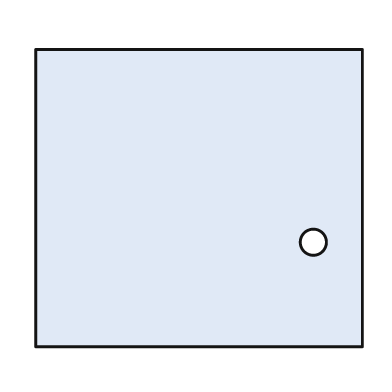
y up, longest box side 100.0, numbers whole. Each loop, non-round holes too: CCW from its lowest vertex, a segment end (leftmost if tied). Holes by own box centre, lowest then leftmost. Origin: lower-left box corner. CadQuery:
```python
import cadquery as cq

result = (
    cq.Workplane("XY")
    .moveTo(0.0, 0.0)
    .lineTo(100.0, 0.0)
    .lineTo(100.0, 91.0)
    .lineTo(0.0, 91.0)
    .close()
    .moveTo(85.0, 32.0)
    .circle(4.0)
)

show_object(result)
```